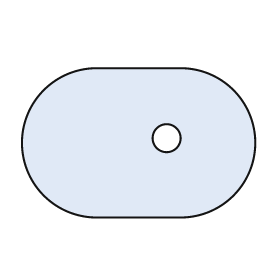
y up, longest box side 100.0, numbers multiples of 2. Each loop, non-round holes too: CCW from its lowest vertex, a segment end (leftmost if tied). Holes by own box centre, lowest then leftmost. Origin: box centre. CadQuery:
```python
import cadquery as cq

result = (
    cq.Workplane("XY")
    .moveTo(-18.0, -32.0)
    .lineTo(18.0, -32.0)
    .threePointArc((50.0, 0.0), (18.0, 32.0))
    .lineTo(-18.0, 32.0)
    .threePointArc((-50.0, 0.0), (-18.0, -32.0))
    .close()
    .moveTo(12.0, 2.0)
    .circle(6.0)
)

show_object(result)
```